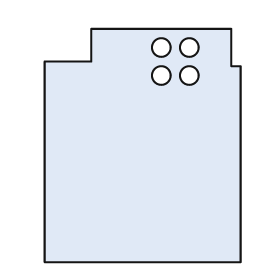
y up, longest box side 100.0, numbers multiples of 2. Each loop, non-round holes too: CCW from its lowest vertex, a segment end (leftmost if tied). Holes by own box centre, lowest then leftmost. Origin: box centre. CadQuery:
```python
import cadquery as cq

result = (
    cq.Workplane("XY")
    .moveTo(-42.0, -50.0)
    .lineTo(42.0, -50.0)
    .lineTo(42.0, 34.0)
    .lineTo(38.0, 34.0)
    .lineTo(38.0, 50.0)
    .lineTo(-22.0, 50.0)
    .lineTo(-22.0, 36.0)
    .lineTo(-42.0, 36.0)
    .close()
    .moveTo(8.0, 30.0)
    .circle(4.0)
    .moveTo(20.0, 30.0)
    .circle(4.0)
    .moveTo(8.0, 42.0)
    .circle(4.0)
    .moveTo(20.0, 42.0)
    .circle(4.0)
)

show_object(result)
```